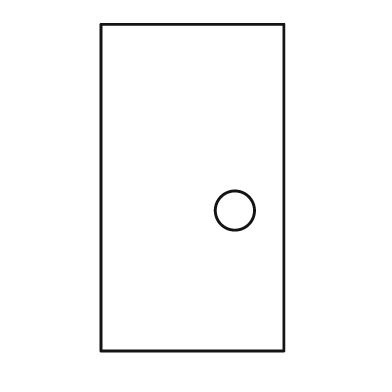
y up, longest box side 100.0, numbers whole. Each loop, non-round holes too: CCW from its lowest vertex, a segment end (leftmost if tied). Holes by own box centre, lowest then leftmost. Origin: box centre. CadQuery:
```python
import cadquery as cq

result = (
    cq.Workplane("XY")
    .moveTo(-28.0, -50.0)
    .lineTo(28.0, -50.0)
    .lineTo(28.0, 50.0)
    .lineTo(-28.0, 50.0)
    .close()
    .moveTo(13.0, -7.0)
    .circle(6.0)
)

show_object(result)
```